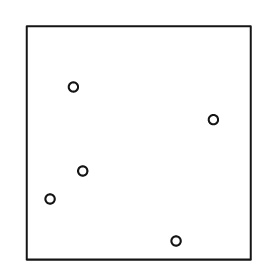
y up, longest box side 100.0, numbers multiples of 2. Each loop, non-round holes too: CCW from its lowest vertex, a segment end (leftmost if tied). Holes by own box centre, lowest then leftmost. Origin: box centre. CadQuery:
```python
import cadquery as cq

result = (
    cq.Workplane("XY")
    .moveTo(-48.0, -50.0)
    .lineTo(48.0, -50.0)
    .lineTo(48.0, 50.0)
    .lineTo(-48.0, 50.0)
    .close()
    .moveTo(16.0, -42.0)
    .circle(2.0)
    .moveTo(-38.0, -24.0)
    .circle(2.0)
    .moveTo(-24.0, -12.0)
    .circle(2.0)
    .moveTo(32.0, 10.0)
    .circle(2.0)
    .moveTo(-28.0, 24.0)
    .circle(2.0)
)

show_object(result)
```